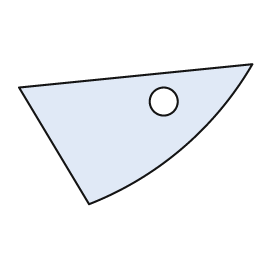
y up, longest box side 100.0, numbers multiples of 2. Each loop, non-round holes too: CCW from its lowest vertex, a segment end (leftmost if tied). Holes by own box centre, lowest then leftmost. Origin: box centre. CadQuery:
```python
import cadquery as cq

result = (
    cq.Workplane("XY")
    .moveTo(-20.0, -30.0)
    .threePointArc((20.0, -6.0), (50.0, 30.0))
    .lineTo(-50.0, 20.0)
    .close()
    .moveTo(12.0, 14.0)
    .circle(6.0)
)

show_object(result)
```